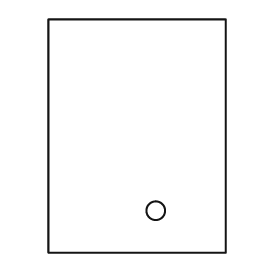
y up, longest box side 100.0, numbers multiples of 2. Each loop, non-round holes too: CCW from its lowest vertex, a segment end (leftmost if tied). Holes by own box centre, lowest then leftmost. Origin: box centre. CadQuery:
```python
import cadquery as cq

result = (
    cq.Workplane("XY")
    .moveTo(-38.0, -50.0)
    .lineTo(38.0, -50.0)
    .lineTo(38.0, 50.0)
    .lineTo(-38.0, 50.0)
    .close()
    .moveTo(8.0, -32.0)
    .circle(4.0)
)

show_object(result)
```